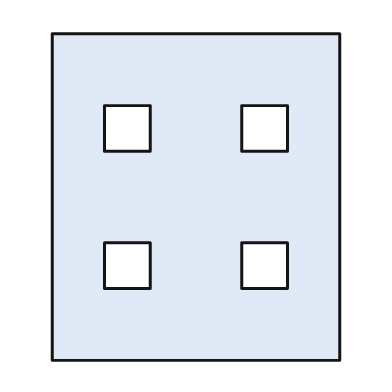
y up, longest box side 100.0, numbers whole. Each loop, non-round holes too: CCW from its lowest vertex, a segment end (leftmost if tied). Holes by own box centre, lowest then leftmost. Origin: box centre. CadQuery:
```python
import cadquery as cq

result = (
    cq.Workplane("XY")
    .moveTo(-44.0, -50.0)
    .lineTo(44.0, -50.0)
    .lineTo(44.0, 50.0)
    .lineTo(-44.0, 50.0)
    .close()
    .moveTo(-28.0, -28.0)
    .lineTo(-14.0, -28.0)
    .lineTo(-14.0, -14.0)
    .lineTo(-28.0, -14.0)
    .close()
    .moveTo(14.0, -28.0)
    .lineTo(28.0, -28.0)
    .lineTo(28.0, -14.0)
    .lineTo(14.0, -14.0)
    .close()
    .moveTo(-28.0, 14.0)
    .lineTo(-14.0, 14.0)
    .lineTo(-14.0, 28.0)
    .lineTo(-28.0, 28.0)
    .close()
    .moveTo(14.0, 14.0)
    .lineTo(28.0, 14.0)
    .lineTo(28.0, 28.0)
    .lineTo(14.0, 28.0)
    .close()
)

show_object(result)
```